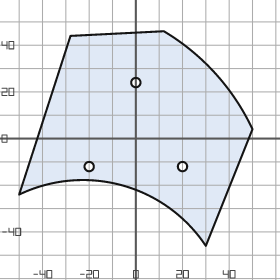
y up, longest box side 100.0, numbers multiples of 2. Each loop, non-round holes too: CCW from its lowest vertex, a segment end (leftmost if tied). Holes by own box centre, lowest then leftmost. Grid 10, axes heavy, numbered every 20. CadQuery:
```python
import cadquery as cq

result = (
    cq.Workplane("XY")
    .moveTo(30.0, -46.0)
    .lineTo(50.0, 4.0)
    .threePointArc((34.0, 28.0), (12.0, 46.0))
    .lineTo(-28.0, 44.0)
    .lineTo(-50.0, -24.0)
    .threePointArc((-6.0, -20.0), (30.0, -46.0))
    .close()
    .moveTo(-20.0, -12.0)
    .circle(2.0)
    .moveTo(20.0, -12.0)
    .circle(2.0)
    .moveTo(0.0, 24.0)
    .circle(2.0)
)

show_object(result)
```